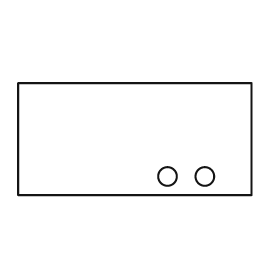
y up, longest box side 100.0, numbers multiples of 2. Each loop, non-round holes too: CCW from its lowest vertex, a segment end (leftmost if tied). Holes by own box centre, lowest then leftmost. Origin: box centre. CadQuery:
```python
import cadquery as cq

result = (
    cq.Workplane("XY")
    .moveTo(-50.0, -24.0)
    .lineTo(50.0, -24.0)
    .lineTo(50.0, 24.0)
    .lineTo(-50.0, 24.0)
    .close()
    .moveTo(14.0, -16.0)
    .circle(4.0)
    .moveTo(30.0, -16.0)
    .circle(4.0)
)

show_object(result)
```